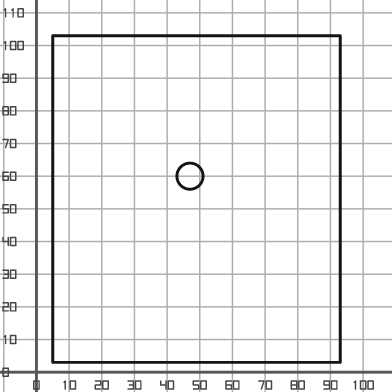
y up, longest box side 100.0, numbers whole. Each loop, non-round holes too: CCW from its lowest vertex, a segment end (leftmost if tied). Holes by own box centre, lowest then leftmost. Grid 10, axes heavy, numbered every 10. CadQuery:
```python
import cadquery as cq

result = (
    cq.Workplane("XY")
    .moveTo(5.0, 3.0)
    .lineTo(93.0, 3.0)
    .lineTo(93.0, 103.0)
    .lineTo(5.0, 103.0)
    .close()
    .moveTo(47.0, 60.0)
    .circle(4.0)
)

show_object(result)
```